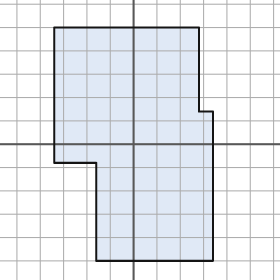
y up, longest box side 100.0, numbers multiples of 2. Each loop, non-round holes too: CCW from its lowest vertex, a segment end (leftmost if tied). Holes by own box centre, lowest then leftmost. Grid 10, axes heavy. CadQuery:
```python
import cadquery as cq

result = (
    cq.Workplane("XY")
    .moveTo(-16.0, -50.0)
    .lineTo(34.0, -50.0)
    .lineTo(34.0, 14.0)
    .lineTo(28.0, 14.0)
    .lineTo(28.0, 50.0)
    .lineTo(-34.0, 50.0)
    .lineTo(-34.0, -8.0)
    .lineTo(-16.0, -8.0)
    .close()
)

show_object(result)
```